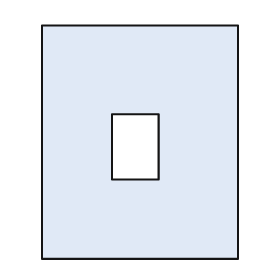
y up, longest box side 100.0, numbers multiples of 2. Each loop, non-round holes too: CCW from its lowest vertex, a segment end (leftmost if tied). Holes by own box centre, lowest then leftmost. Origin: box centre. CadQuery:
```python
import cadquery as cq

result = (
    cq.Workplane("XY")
    .moveTo(-42.0, -50.0)
    .lineTo(42.0, -50.0)
    .lineTo(42.0, 50.0)
    .lineTo(-42.0, 50.0)
    .close()
    .moveTo(-12.0, -16.0)
    .lineTo(8.0, -16.0)
    .lineTo(8.0, 12.0)
    .lineTo(-12.0, 12.0)
    .close()
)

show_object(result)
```